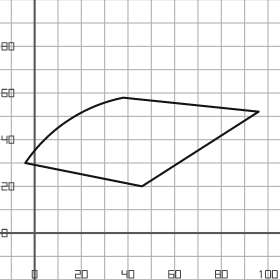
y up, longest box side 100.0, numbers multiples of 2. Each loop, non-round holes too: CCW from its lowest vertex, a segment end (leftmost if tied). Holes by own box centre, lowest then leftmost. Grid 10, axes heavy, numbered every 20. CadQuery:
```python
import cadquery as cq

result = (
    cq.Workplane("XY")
    .moveTo(46.0, 20.0)
    .lineTo(96.0, 52.0)
    .lineTo(38.0, 58.0)
    .threePointArc((14.0, 48.0), (-4.0, 30.0))
    .close()
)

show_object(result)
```